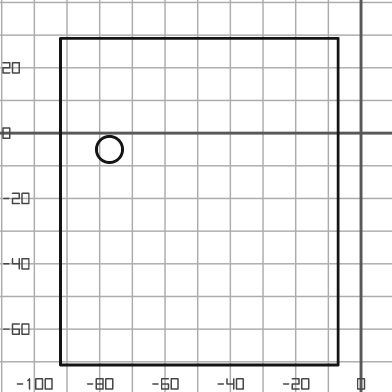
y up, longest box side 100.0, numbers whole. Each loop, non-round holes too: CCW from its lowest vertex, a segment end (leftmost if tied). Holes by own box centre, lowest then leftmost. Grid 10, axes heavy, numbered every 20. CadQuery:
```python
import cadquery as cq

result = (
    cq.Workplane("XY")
    .moveTo(-92.0, -71.0)
    .lineTo(-7.0, -71.0)
    .lineTo(-7.0, 29.0)
    .lineTo(-92.0, 29.0)
    .close()
    .moveTo(-77.0, -5.0)
    .circle(4.0)
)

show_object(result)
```